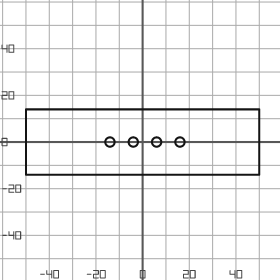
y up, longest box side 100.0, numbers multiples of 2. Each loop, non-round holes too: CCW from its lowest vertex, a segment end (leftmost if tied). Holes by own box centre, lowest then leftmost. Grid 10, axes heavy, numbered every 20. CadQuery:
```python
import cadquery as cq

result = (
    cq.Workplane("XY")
    .moveTo(-50.0, -14.0)
    .lineTo(50.0, -14.0)
    .lineTo(50.0, 14.0)
    .lineTo(-50.0, 14.0)
    .close()
    .moveTo(-14.0, 0.0)
    .circle(2.0)
    .moveTo(-4.0, 0.0)
    .circle(2.0)
    .moveTo(6.0, 0.0)
    .circle(2.0)
    .moveTo(16.0, 0.0)
    .circle(2.0)
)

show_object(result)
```